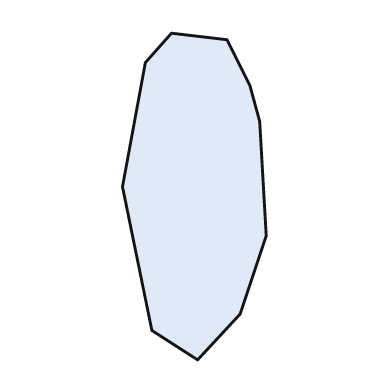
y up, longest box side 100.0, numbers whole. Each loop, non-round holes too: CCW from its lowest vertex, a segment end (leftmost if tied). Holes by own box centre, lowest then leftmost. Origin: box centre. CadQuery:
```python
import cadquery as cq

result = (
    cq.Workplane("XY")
    .moveTo(1.0, -50.0)
    .lineTo(14.0, -36.0)
    .lineTo(22.0, -12.0)
    .lineTo(20.0, 23.0)
    .lineTo(17.0, 34.0)
    .lineTo(10.0, 48.0)
    .lineTo(-7.0, 50.0)
    .lineTo(-15.0, 41.0)
    .lineTo(-22.0, 3.0)
    .lineTo(-13.0, -41.0)
    .close()
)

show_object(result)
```